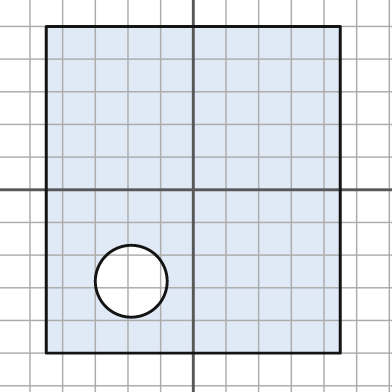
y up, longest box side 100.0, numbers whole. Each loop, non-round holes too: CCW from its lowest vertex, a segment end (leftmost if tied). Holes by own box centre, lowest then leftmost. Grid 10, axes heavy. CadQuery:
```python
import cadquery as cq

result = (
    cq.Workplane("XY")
    .moveTo(-45.0, -50.0)
    .lineTo(45.0, -50.0)
    .lineTo(45.0, 50.0)
    .lineTo(-45.0, 50.0)
    .close()
    .moveTo(-19.0, -28.0)
    .circle(11.0)
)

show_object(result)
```